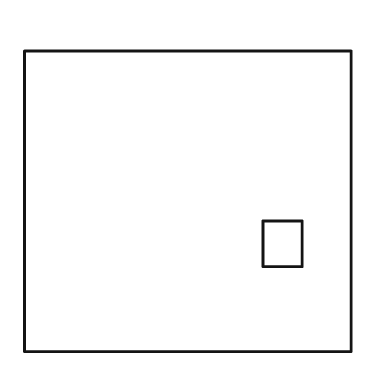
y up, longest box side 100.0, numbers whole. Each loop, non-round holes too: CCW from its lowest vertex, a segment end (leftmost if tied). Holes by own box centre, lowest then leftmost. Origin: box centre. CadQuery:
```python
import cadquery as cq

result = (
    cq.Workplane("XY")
    .moveTo(-50.0, -46.0)
    .lineTo(50.0, -46.0)
    .lineTo(50.0, 46.0)
    .lineTo(-50.0, 46.0)
    .close()
    .moveTo(23.0, -20.0)
    .lineTo(35.0, -20.0)
    .lineTo(35.0, -6.0)
    .lineTo(23.0, -6.0)
    .close()
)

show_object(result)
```